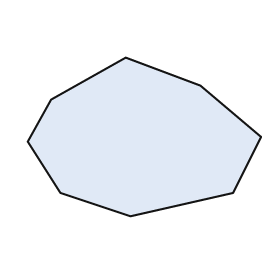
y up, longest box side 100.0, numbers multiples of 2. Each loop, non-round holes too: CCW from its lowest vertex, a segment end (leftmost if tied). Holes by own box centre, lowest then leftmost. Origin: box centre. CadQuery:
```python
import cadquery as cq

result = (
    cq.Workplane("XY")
    .moveTo(-6.0, -34.0)
    .lineTo(38.0, -24.0)
    .lineTo(50.0, 0.0)
    .lineTo(24.0, 22.0)
    .lineTo(-8.0, 34.0)
    .lineTo(-40.0, 16.0)
    .lineTo(-50.0, -2.0)
    .lineTo(-36.0, -24.0)
    .close()
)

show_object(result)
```